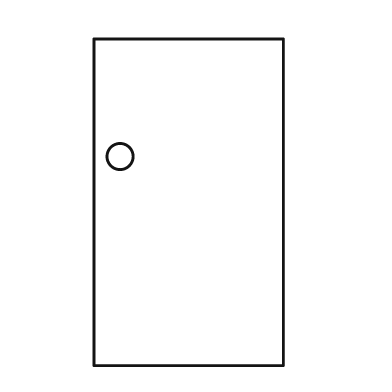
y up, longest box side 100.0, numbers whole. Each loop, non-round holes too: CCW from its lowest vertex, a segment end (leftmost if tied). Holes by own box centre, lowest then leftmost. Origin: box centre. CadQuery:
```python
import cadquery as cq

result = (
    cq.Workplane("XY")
    .moveTo(-29.0, -50.0)
    .lineTo(29.0, -50.0)
    .lineTo(29.0, 50.0)
    .lineTo(-29.0, 50.0)
    .close()
    .moveTo(-21.0, 14.0)
    .circle(4.0)
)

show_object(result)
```